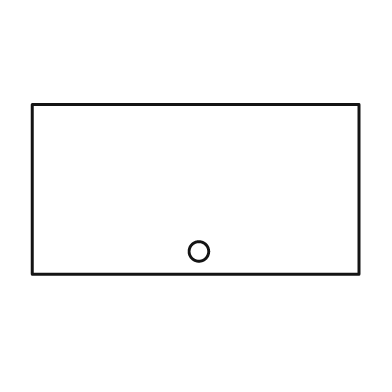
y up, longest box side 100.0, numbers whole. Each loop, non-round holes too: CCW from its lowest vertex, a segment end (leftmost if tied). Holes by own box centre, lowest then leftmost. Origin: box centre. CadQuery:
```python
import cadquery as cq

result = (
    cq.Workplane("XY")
    .moveTo(-50.0, -26.0)
    .lineTo(50.0, -26.0)
    .lineTo(50.0, 26.0)
    .lineTo(-50.0, 26.0)
    .close()
    .moveTo(1.0, -19.0)
    .circle(3.0)
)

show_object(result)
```